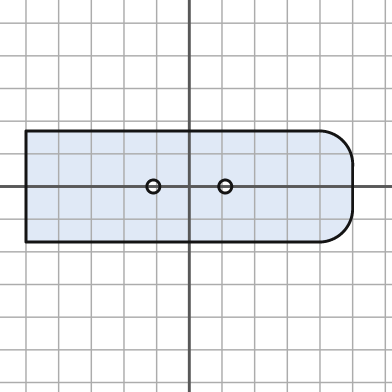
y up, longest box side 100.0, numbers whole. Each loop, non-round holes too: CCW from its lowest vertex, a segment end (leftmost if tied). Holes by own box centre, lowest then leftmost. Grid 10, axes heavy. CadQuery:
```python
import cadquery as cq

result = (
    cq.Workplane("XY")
    .moveTo(-50.0, -17.0)
    .lineTo(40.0, -17.0)
    .threePointArc((47.0, -14.0), (50.0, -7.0))
    .lineTo(50.0, 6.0)
    .threePointArc((47.0, 14.0), (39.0, 17.0))
    .lineTo(-50.0, 17.0)
    .close()
    .moveTo(-11.0, 0.0)
    .circle(2.0)
    .moveTo(11.0, 0.0)
    .circle(2.0)
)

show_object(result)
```